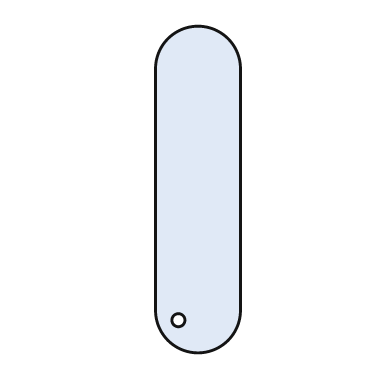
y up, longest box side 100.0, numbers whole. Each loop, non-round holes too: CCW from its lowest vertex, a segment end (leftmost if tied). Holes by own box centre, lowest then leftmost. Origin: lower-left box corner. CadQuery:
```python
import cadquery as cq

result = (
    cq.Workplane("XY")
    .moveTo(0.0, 13.0)
    .threePointArc((13.0, 0.0), (26.0, 13.0))
    .lineTo(26.0, 87.0)
    .threePointArc((13.0, 100.0), (0.0, 87.0))
    .close()
    .moveTo(7.0, 10.0)
    .circle(2.0)
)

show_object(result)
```